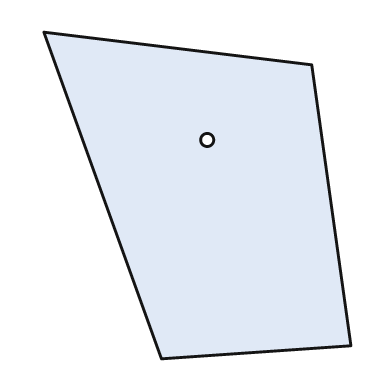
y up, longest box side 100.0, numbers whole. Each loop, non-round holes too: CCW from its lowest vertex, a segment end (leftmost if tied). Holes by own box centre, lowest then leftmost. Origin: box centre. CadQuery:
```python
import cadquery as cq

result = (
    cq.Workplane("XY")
    .moveTo(-11.0, -50.0)
    .lineTo(47.0, -46.0)
    .lineTo(35.0, 40.0)
    .lineTo(-47.0, 50.0)
    .close()
    .moveTo(3.0, 17.0)
    .circle(2.0)
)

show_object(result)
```